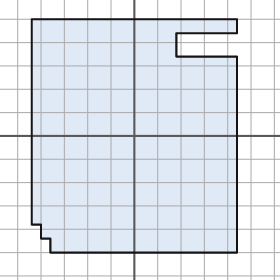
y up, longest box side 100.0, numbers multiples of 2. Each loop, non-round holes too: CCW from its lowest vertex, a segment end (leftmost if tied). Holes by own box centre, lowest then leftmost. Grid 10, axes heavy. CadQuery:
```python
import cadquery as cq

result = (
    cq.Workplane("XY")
    .moveTo(-36.0, -50.0)
    .lineTo(44.0, -50.0)
    .lineTo(44.0, 34.0)
    .lineTo(18.0, 34.0)
    .lineTo(18.0, 44.0)
    .lineTo(44.0, 44.0)
    .lineTo(44.0, 50.0)
    .lineTo(-44.0, 50.0)
    .lineTo(-44.0, -38.0)
    .lineTo(-40.0, -38.0)
    .lineTo(-40.0, -44.0)
    .lineTo(-36.0, -44.0)
    .close()
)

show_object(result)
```